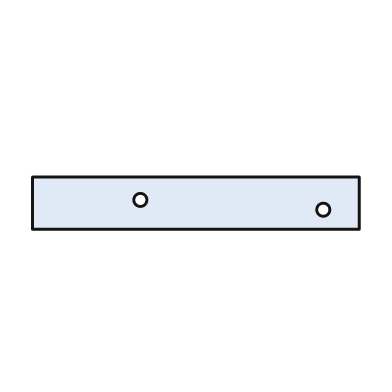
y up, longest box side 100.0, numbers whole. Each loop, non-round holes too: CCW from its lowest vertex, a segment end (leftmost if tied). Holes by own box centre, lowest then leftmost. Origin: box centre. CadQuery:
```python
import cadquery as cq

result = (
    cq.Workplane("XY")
    .moveTo(-50.0, -8.0)
    .lineTo(50.0, -8.0)
    .lineTo(50.0, 8.0)
    .lineTo(-50.0, 8.0)
    .close()
    .moveTo(39.0, -2.0)
    .circle(2.0)
    .moveTo(-17.0, 1.0)
    .circle(2.0)
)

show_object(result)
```